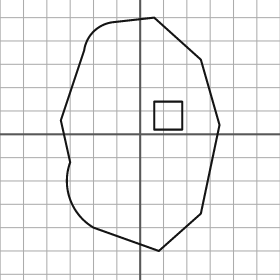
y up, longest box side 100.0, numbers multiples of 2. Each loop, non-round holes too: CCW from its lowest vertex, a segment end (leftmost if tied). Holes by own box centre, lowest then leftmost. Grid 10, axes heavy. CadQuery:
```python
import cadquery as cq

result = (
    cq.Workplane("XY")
    .moveTo(8.0, -50.0)
    .lineTo(26.0, -34.0)
    .lineTo(34.0, 4.0)
    .lineTo(26.0, 32.0)
    .lineTo(6.0, 50.0)
    .lineTo(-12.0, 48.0)
    .threePointArc((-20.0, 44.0), (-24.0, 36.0))
    .lineTo(-34.0, 6.0)
    .lineTo(-30.0, -12.0)
    .threePointArc((-30.0, -28.0), (-20.0, -40.0))
    .close()
    .moveTo(6.0, 2.0)
    .lineTo(18.0, 2.0)
    .lineTo(18.0, 14.0)
    .lineTo(6.0, 14.0)
    .close()
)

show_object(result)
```